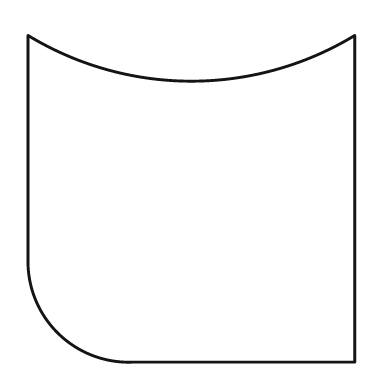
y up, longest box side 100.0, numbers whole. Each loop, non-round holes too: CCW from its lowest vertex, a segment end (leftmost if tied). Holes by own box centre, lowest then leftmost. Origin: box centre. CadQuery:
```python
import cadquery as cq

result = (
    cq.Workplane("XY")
    .moveTo(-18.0, -50.0)
    .lineTo(50.0, -50.0)
    .lineTo(50.0, 50.0)
    .threePointArc((0.0, 36.0), (-50.0, 50.0))
    .lineTo(-50.0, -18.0)
    .threePointArc((-41.0, -41.0), (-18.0, -50.0))
    .close()
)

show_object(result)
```